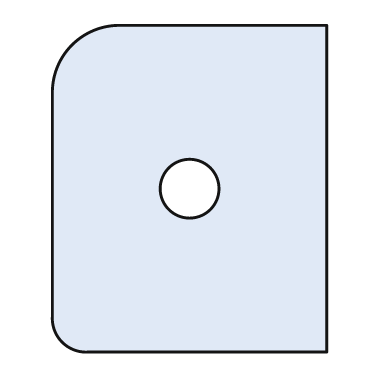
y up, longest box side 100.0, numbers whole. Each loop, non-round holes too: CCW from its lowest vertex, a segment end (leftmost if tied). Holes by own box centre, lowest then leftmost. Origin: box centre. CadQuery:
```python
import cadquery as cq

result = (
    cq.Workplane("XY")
    .moveTo(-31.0, -50.0)
    .lineTo(42.0, -50.0)
    .lineTo(42.0, 50.0)
    .lineTo(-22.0, 50.0)
    .threePointArc((-36.0, 44.0), (-42.0, 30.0))
    .lineTo(-42.0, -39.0)
    .threePointArc((-39.0, -47.0), (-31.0, -50.0))
    .close()
    .moveTo(0.0, 0.0)
    .circle(9.0)
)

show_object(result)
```